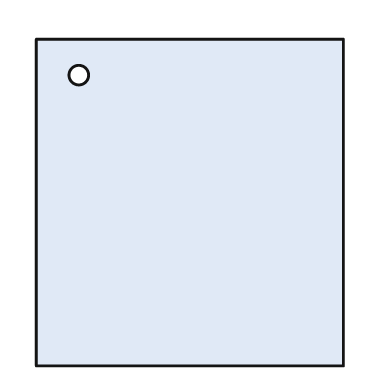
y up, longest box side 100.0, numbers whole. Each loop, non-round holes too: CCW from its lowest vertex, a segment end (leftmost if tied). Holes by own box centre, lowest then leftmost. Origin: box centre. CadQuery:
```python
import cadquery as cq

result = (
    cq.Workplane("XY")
    .moveTo(-47.0, -50.0)
    .lineTo(47.0, -50.0)
    .lineTo(47.0, 50.0)
    .lineTo(-47.0, 50.0)
    .close()
    .moveTo(-34.0, 39.0)
    .circle(3.0)
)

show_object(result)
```